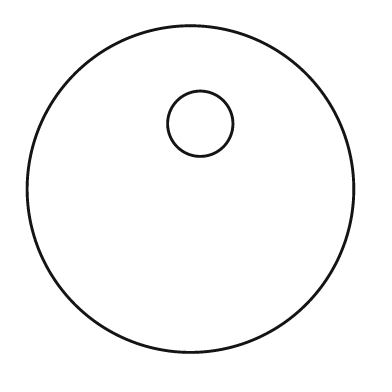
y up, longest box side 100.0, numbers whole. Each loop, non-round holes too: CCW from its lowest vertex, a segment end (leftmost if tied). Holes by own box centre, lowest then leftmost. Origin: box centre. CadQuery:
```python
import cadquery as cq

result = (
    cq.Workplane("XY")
    .moveTo(0.0, 0.0)
    .circle(50.0)
    .moveTo(3.0, 20.0)
    .circle(10.0)
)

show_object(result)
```